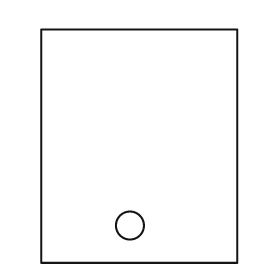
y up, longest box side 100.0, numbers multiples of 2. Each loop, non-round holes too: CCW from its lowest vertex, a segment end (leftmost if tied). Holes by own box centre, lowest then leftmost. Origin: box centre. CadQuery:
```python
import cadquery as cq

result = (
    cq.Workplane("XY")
    .moveTo(-42.0, -50.0)
    .lineTo(42.0, -50.0)
    .lineTo(42.0, 50.0)
    .lineTo(-42.0, 50.0)
    .close()
    .moveTo(-4.0, -34.0)
    .circle(6.0)
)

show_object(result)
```